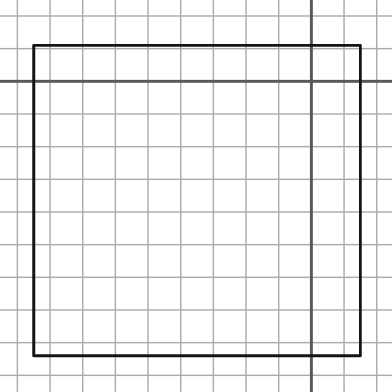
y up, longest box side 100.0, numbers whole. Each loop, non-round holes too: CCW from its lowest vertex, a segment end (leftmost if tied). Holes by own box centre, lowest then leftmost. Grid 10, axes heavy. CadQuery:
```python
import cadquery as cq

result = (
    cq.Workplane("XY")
    .moveTo(-85.0, -84.0)
    .lineTo(15.0, -84.0)
    .lineTo(15.0, 11.0)
    .lineTo(-85.0, 11.0)
    .close()
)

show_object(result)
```